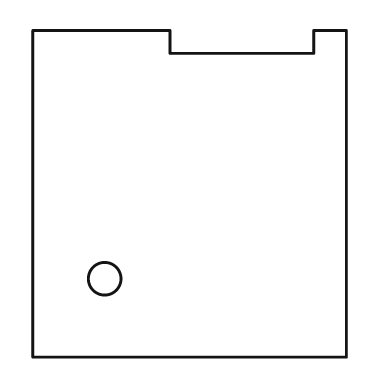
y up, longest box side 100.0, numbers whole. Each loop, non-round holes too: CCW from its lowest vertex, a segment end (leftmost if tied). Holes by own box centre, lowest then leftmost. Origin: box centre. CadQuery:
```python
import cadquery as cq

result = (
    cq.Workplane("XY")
    .moveTo(-48.0, -50.0)
    .lineTo(48.0, -50.0)
    .lineTo(48.0, 50.0)
    .lineTo(38.0, 50.0)
    .lineTo(38.0, 43.0)
    .lineTo(-6.0, 43.0)
    .lineTo(-6.0, 50.0)
    .lineTo(-48.0, 50.0)
    .close()
    .moveTo(-26.0, -26.0)
    .circle(5.0)
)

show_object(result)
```